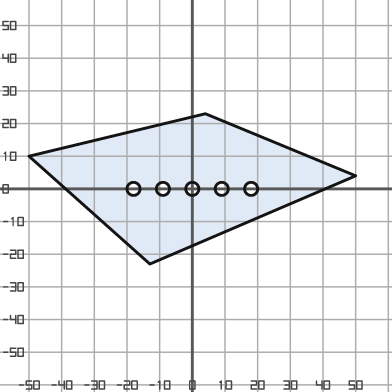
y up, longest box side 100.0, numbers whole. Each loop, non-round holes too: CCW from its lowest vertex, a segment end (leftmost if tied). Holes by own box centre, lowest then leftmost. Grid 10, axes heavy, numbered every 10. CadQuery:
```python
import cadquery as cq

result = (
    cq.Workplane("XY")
    .moveTo(-13.0, -23.0)
    .lineTo(50.0, 4.0)
    .lineTo(4.0, 23.0)
    .lineTo(-50.0, 10.0)
    .close()
    .moveTo(-18.0, 0.0)
    .circle(2.0)
    .moveTo(-9.0, 0.0)
    .circle(2.0)
    .moveTo(0.0, 0.0)
    .circle(2.0)
    .moveTo(9.0, 0.0)
    .circle(2.0)
    .moveTo(18.0, 0.0)
    .circle(2.0)
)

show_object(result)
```